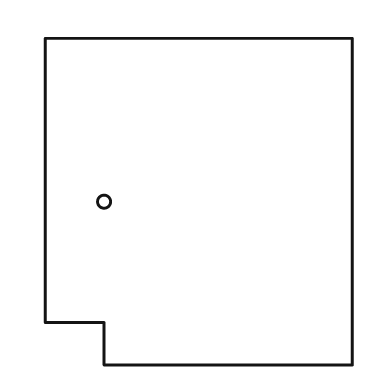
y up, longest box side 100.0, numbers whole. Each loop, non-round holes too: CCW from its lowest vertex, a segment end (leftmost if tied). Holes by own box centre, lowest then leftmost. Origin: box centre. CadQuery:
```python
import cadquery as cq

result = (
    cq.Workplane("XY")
    .moveTo(-29.0, -50.0)
    .lineTo(47.0, -50.0)
    .lineTo(47.0, 50.0)
    .lineTo(-47.0, 50.0)
    .lineTo(-47.0, -37.0)
    .lineTo(-29.0, -37.0)
    .close()
    .moveTo(-29.0, 0.0)
    .circle(2.0)
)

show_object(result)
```